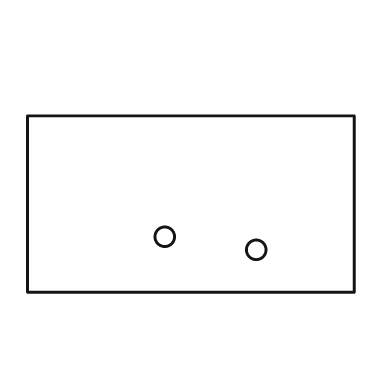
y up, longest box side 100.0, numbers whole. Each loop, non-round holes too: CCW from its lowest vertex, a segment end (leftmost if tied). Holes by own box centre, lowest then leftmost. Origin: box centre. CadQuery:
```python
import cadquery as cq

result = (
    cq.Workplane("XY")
    .moveTo(-50.0, -27.0)
    .lineTo(50.0, -27.0)
    .lineTo(50.0, 27.0)
    .lineTo(-50.0, 27.0)
    .close()
    .moveTo(20.0, -14.0)
    .circle(3.0)
    .moveTo(-8.0, -10.0)
    .circle(3.0)
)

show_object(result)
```